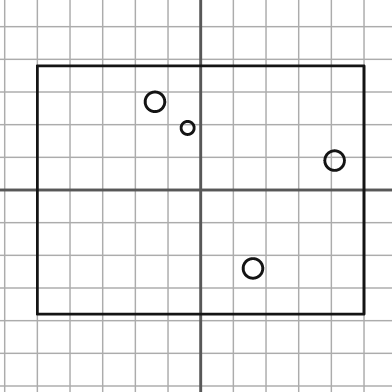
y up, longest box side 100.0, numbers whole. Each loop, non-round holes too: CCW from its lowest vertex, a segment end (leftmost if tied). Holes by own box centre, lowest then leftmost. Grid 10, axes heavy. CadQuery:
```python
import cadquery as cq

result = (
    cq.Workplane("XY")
    .moveTo(-50.0, -38.0)
    .lineTo(50.0, -38.0)
    .lineTo(50.0, 38.0)
    .lineTo(-50.0, 38.0)
    .close()
    .moveTo(16.0, -24.0)
    .circle(3.0)
    .moveTo(41.0, 9.0)
    .circle(3.0)
    .moveTo(-4.0, 19.0)
    .circle(2.0)
    .moveTo(-14.0, 27.0)
    .circle(3.0)
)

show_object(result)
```